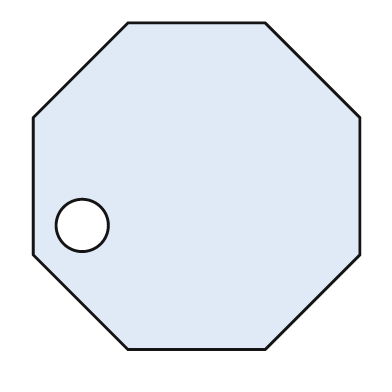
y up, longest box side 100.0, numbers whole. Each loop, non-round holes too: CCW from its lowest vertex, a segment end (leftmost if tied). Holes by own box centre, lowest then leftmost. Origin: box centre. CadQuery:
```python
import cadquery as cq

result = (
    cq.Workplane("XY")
    .moveTo(-21.0, -50.0)
    .lineTo(21.0, -50.0)
    .lineTo(50.0, -21.0)
    .lineTo(50.0, 21.0)
    .lineTo(21.0, 50.0)
    .lineTo(-21.0, 50.0)
    .lineTo(-50.0, 21.0)
    .lineTo(-50.0, -21.0)
    .close()
    .moveTo(-35.0, -12.0)
    .circle(8.0)
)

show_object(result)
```